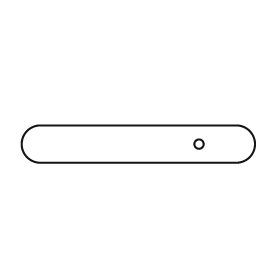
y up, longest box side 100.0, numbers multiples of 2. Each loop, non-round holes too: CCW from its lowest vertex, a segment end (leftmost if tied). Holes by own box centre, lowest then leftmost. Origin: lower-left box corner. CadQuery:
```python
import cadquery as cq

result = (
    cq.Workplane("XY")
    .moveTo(8.0, 0.0)
    .lineTo(92.0, 0.0)
    .threePointArc((100.0, 8.0), (92.0, 16.0))
    .lineTo(8.0, 16.0)
    .threePointArc((0.0, 8.0), (8.0, 0.0))
    .close()
    .moveTo(76.0, 8.0)
    .circle(2.0)
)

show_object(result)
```